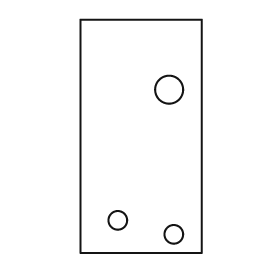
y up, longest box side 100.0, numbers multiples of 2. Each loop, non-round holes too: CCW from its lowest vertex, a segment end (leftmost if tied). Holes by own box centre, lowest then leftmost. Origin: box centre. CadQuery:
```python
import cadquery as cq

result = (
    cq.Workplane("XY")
    .moveTo(-26.0, -50.0)
    .lineTo(26.0, -50.0)
    .lineTo(26.0, 50.0)
    .lineTo(-26.0, 50.0)
    .close()
    .moveTo(14.0, -42.0)
    .circle(4.0)
    .moveTo(-10.0, -36.0)
    .circle(4.0)
    .moveTo(12.0, 20.0)
    .circle(6.0)
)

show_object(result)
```